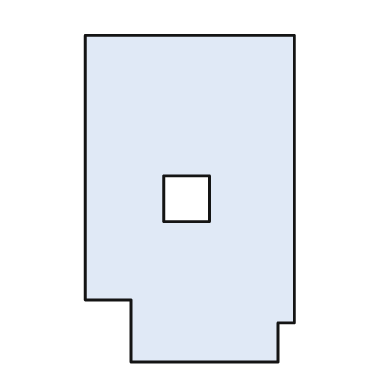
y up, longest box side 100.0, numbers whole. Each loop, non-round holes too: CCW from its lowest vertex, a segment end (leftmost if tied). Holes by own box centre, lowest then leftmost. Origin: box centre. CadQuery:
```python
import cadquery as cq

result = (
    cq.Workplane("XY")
    .moveTo(-18.0, -50.0)
    .lineTo(27.0, -50.0)
    .lineTo(27.0, -38.0)
    .lineTo(32.0, -38.0)
    .lineTo(32.0, 50.0)
    .lineTo(-32.0, 50.0)
    .lineTo(-32.0, -31.0)
    .lineTo(-18.0, -31.0)
    .close()
    .moveTo(-8.0, -7.0)
    .lineTo(6.0, -7.0)
    .lineTo(6.0, 7.0)
    .lineTo(-8.0, 7.0)
    .close()
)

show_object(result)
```